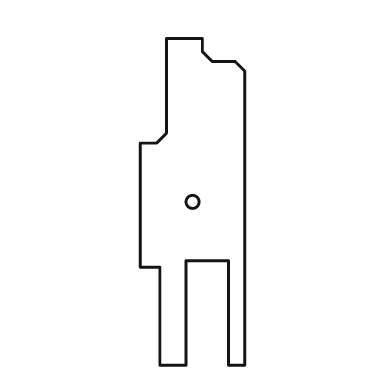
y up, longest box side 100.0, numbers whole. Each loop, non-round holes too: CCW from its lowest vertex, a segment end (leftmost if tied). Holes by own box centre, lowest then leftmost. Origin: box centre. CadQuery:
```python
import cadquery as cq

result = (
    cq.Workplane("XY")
    .moveTo(-10.0, -50.0)
    .lineTo(-2.0, -50.0)
    .lineTo(-2.0, -18.0)
    .lineTo(11.0, -18.0)
    .lineTo(11.0, -50.0)
    .lineTo(16.0, -50.0)
    .lineTo(16.0, 40.0)
    .lineTo(13.0, 43.0)
    .lineTo(6.0, 43.0)
    .lineTo(3.0, 46.0)
    .lineTo(3.0, 50.0)
    .lineTo(-8.0, 50.0)
    .lineTo(-8.0, 21.0)
    .lineTo(-11.0, 18.0)
    .lineTo(-16.0, 18.0)
    .lineTo(-16.0, -20.0)
    .lineTo(-10.0, -20.0)
    .close()
    .moveTo(0.0, 0.0)
    .circle(2.0)
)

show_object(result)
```